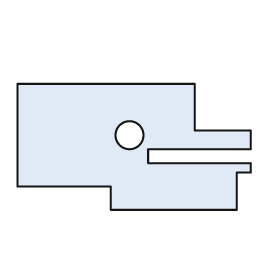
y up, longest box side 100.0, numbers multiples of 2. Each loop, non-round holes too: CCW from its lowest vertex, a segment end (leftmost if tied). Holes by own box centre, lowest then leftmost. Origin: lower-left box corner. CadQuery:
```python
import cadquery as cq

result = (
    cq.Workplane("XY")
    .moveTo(40.0, 0.0)
    .lineTo(94.0, 0.0)
    .lineTo(94.0, 16.0)
    .lineTo(100.0, 16.0)
    .lineTo(100.0, 20.0)
    .lineTo(56.0, 20.0)
    .lineTo(56.0, 26.0)
    .lineTo(100.0, 26.0)
    .lineTo(100.0, 34.0)
    .lineTo(76.0, 34.0)
    .lineTo(76.0, 54.0)
    .lineTo(0.0, 54.0)
    .lineTo(0.0, 10.0)
    .lineTo(40.0, 10.0)
    .close()
    .moveTo(48.0, 32.0)
    .circle(6.0)
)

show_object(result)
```